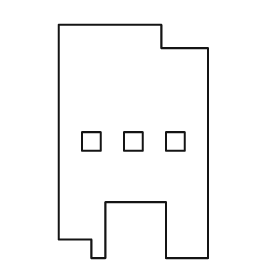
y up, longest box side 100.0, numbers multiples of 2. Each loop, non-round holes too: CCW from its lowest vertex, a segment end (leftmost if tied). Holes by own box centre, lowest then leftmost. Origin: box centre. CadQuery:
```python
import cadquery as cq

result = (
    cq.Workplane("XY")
    .moveTo(-18.0, -50.0)
    .lineTo(-12.0, -50.0)
    .lineTo(-12.0, -26.0)
    .lineTo(14.0, -26.0)
    .lineTo(14.0, -50.0)
    .lineTo(32.0, -50.0)
    .lineTo(32.0, 40.0)
    .lineTo(12.0, 40.0)
    .lineTo(12.0, 50.0)
    .lineTo(-32.0, 50.0)
    .lineTo(-32.0, -42.0)
    .lineTo(-18.0, -42.0)
    .close()
    .moveTo(-22.0, -4.0)
    .lineTo(-14.0, -4.0)
    .lineTo(-14.0, 4.0)
    .lineTo(-22.0, 4.0)
    .close()
    .moveTo(-4.0, -4.0)
    .lineTo(4.0, -4.0)
    .lineTo(4.0, 4.0)
    .lineTo(-4.0, 4.0)
    .close()
    .moveTo(14.0, -4.0)
    .lineTo(22.0, -4.0)
    .lineTo(22.0, 4.0)
    .lineTo(14.0, 4.0)
    .close()
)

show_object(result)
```